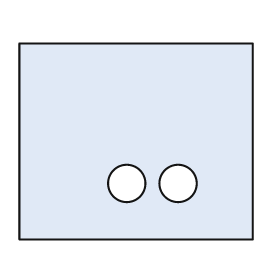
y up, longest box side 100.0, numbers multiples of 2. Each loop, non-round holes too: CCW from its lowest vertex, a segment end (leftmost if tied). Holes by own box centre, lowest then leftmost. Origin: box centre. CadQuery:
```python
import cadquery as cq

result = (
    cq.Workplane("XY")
    .moveTo(-50.0, -42.0)
    .lineTo(50.0, -42.0)
    .lineTo(50.0, 42.0)
    .lineTo(-50.0, 42.0)
    .close()
    .moveTo(-4.0, -18.0)
    .circle(8.0)
    .moveTo(18.0, -18.0)
    .circle(8.0)
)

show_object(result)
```